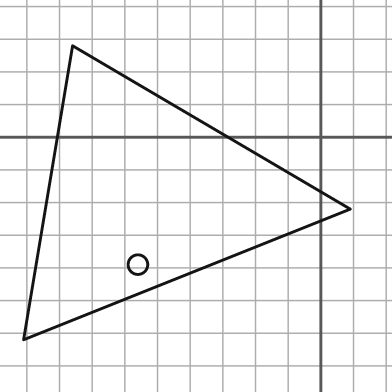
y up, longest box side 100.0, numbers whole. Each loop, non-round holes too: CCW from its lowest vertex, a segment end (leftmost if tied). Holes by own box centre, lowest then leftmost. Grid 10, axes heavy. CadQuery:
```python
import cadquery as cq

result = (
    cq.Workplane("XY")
    .moveTo(-91.0, -62.0)
    .lineTo(9.0, -22.0)
    .lineTo(-76.0, 28.0)
    .close()
    .moveTo(-56.0, -39.0)
    .circle(3.0)
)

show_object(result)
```